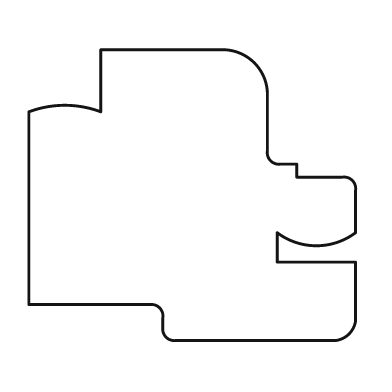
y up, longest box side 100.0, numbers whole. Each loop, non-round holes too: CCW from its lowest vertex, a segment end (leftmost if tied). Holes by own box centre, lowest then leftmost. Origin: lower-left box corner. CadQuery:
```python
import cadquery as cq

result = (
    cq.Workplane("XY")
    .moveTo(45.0, 0.0)
    .lineTo(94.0, 0.0)
    .threePointArc((98.0, 2.0), (100.0, 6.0))
    .lineTo(100.0, 24.0)
    .lineTo(76.0, 24.0)
    .lineTo(76.0, 33.0)
    .threePointArc((88.0, 29.0), (100.0, 33.0))
    .lineTo(100.0, 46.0)
    .threePointArc((99.0, 49.0), (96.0, 50.0))
    .lineTo(82.0, 50.0)
    .lineTo(82.0, 54.0)
    .lineTo(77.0, 54.0)
    .threePointArc((74.0, 55.0), (73.0, 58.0))
    .lineTo(73.0, 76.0)
    .threePointArc((69.0, 85.0), (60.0, 89.0))
    .lineTo(22.0, 89.0)
    .lineTo(22.0, 70.0)
    .threePointArc((11.0, 72.0), (0.0, 70.0))
    .lineTo(0.0, 11.0)
    .lineTo(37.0, 11.0)
    .threePointArc((40.0, 10.0), (41.0, 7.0))
    .lineTo(41.0, 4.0)
    .threePointArc((42.0, 1.0), (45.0, 0.0))
    .close()
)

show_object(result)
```